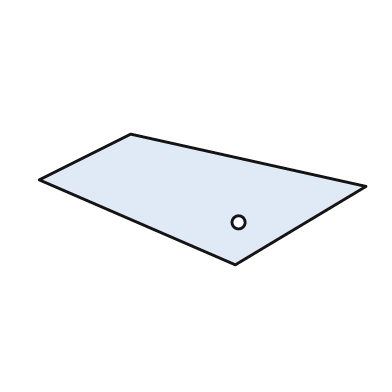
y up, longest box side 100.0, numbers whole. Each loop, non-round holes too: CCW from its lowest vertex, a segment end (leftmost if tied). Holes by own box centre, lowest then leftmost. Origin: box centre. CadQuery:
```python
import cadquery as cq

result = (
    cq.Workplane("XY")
    .moveTo(10.0, -20.0)
    .lineTo(50.0, 4.0)
    .lineTo(-22.0, 20.0)
    .lineTo(-50.0, 6.0)
    .close()
    .moveTo(11.0, -7.0)
    .circle(2.0)
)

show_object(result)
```